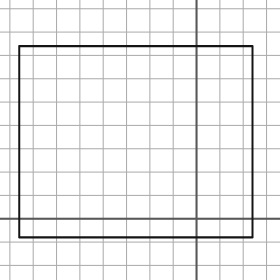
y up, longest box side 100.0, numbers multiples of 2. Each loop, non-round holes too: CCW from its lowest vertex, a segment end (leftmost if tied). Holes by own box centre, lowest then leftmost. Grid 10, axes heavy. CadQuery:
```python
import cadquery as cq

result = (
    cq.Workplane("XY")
    .moveTo(-76.0, -8.0)
    .lineTo(24.0, -8.0)
    .lineTo(24.0, 74.0)
    .lineTo(-76.0, 74.0)
    .close()
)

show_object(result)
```